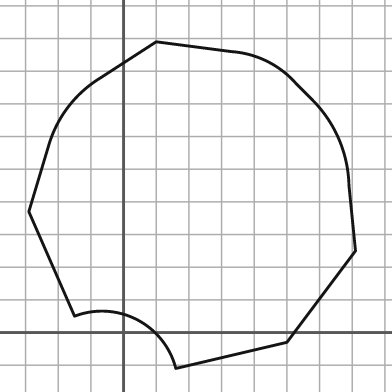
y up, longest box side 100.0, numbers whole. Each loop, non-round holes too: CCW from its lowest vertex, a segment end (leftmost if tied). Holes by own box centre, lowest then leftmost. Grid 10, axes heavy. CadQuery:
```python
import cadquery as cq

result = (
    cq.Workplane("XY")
    .moveTo(16.0, -11.0)
    .lineTo(50.0, -3.0)
    .lineTo(71.0, 25.0)
    .lineTo(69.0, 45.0)
    .threePointArc((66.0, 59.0), (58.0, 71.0))
    .lineTo(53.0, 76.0)
    .threePointArc((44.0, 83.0), (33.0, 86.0))
    .lineTo(10.0, 89.0)
    .lineTo(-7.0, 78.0)
    .threePointArc((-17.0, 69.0), (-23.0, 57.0))
    .lineTo(-29.0, 37.0)
    .lineTo(-15.0, 5.0)
    .threePointArc((4.0, 4.0), (16.0, -11.0))
    .close()
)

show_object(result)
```